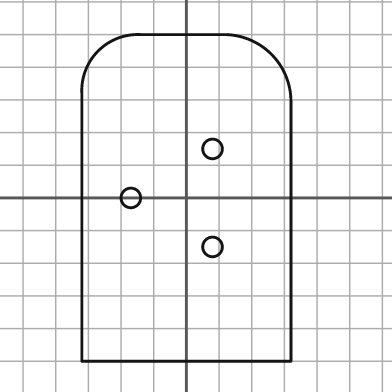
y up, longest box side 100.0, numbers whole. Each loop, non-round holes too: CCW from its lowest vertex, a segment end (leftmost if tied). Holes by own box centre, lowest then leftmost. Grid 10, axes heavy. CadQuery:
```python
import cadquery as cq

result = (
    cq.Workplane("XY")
    .moveTo(-32.0, -50.0)
    .lineTo(32.0, -50.0)
    .lineTo(32.0, 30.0)
    .threePointArc((26.0, 44.0), (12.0, 50.0))
    .lineTo(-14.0, 50.0)
    .threePointArc((-27.0, 45.0), (-32.0, 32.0))
    .close()
    .moveTo(8.0, -15.0)
    .circle(3.0)
    .moveTo(-17.0, 0.0)
    .circle(3.0)
    .moveTo(8.0, 15.0)
    .circle(3.0)
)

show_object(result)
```